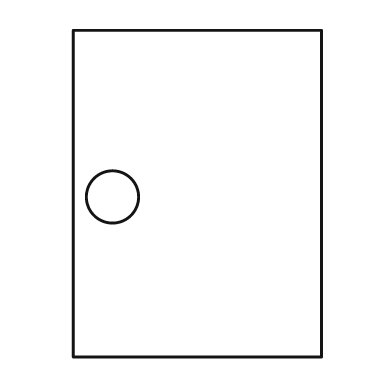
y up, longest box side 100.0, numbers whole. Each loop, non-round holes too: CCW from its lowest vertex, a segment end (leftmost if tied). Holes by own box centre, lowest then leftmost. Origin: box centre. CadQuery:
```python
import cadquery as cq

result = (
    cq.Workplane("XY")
    .moveTo(-38.0, -50.0)
    .lineTo(38.0, -50.0)
    .lineTo(38.0, 50.0)
    .lineTo(-38.0, 50.0)
    .close()
    .moveTo(-26.0, -1.0)
    .circle(8.0)
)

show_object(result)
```